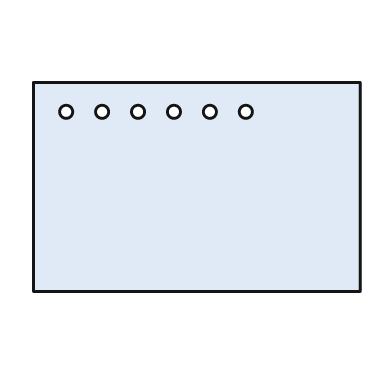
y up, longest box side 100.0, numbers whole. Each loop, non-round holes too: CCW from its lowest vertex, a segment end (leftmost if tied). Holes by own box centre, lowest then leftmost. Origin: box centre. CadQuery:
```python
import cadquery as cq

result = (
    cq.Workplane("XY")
    .moveTo(-50.0, -32.0)
    .lineTo(50.0, -32.0)
    .lineTo(50.0, 32.0)
    .lineTo(-50.0, 32.0)
    .close()
    .moveTo(-40.0, 23.0)
    .circle(2.0)
    .moveTo(-29.0, 23.0)
    .circle(2.0)
    .moveTo(-18.0, 23.0)
    .circle(2.0)
    .moveTo(-7.0, 23.0)
    .circle(2.0)
    .moveTo(4.0, 23.0)
    .circle(2.0)
    .moveTo(15.0, 23.0)
    .circle(2.0)
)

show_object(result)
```